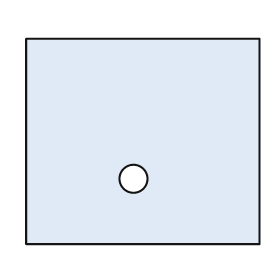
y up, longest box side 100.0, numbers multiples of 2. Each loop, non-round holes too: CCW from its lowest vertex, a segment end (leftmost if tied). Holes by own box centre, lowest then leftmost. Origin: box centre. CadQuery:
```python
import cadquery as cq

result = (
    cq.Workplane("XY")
    .moveTo(-50.0, -44.0)
    .lineTo(50.0, -44.0)
    .lineTo(50.0, 44.0)
    .lineTo(-50.0, 44.0)
    .close()
    .moveTo(-4.0, -16.0)
    .circle(6.0)
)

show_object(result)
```